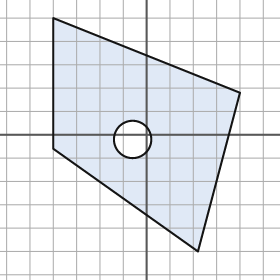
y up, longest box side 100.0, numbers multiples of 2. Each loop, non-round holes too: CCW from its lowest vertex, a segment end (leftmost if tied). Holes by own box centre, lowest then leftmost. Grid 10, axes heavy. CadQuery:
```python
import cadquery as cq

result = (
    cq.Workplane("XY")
    .moveTo(22.0, -50.0)
    .lineTo(40.0, 18.0)
    .lineTo(-40.0, 50.0)
    .lineTo(-40.0, -6.0)
    .close()
    .moveTo(-6.0, -2.0)
    .circle(8.0)
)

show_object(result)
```